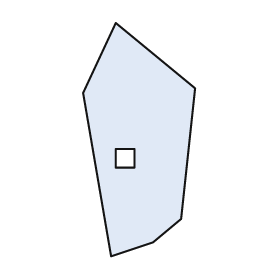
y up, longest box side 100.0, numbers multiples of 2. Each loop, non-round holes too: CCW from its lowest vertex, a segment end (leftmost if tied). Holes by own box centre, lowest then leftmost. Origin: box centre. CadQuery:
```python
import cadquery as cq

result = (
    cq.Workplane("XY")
    .moveTo(-12.0, -50.0)
    .lineTo(6.0, -44.0)
    .lineTo(18.0, -34.0)
    .lineTo(24.0, 22.0)
    .lineTo(-10.0, 50.0)
    .lineTo(-24.0, 20.0)
    .close()
    .moveTo(-10.0, -12.0)
    .lineTo(-2.0, -12.0)
    .lineTo(-2.0, -4.0)
    .lineTo(-10.0, -4.0)
    .close()
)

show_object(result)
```